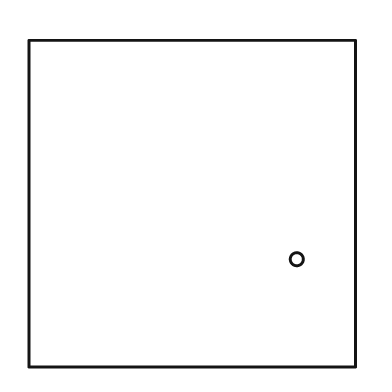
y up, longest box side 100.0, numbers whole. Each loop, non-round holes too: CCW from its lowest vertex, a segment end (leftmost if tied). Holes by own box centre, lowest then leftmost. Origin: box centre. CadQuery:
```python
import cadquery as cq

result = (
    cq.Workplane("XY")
    .moveTo(-50.0, -50.0)
    .lineTo(50.0, -50.0)
    .lineTo(50.0, 50.0)
    .lineTo(-50.0, 50.0)
    .close()
    .moveTo(32.0, -17.0)
    .circle(2.0)
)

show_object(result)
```